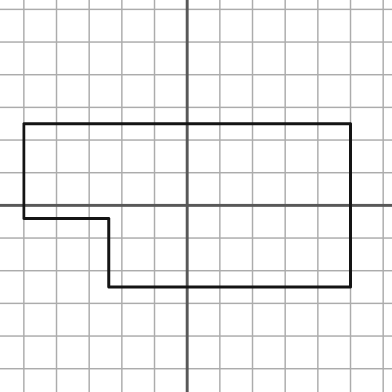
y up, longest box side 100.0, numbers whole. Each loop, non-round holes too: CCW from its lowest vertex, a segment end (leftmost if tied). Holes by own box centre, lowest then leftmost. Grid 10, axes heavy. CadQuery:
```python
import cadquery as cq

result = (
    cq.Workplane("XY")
    .moveTo(-24.0, -25.0)
    .lineTo(50.0, -25.0)
    .lineTo(50.0, 25.0)
    .lineTo(-50.0, 25.0)
    .lineTo(-50.0, -4.0)
    .lineTo(-24.0, -4.0)
    .close()
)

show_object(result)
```